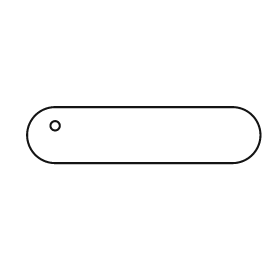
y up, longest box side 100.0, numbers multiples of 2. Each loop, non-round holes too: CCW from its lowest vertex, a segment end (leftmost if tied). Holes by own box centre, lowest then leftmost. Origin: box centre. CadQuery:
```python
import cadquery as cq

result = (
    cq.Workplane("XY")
    .moveTo(-38.0, -12.0)
    .lineTo(38.0, -12.0)
    .threePointArc((50.0, 0.0), (38.0, 12.0))
    .lineTo(-38.0, 12.0)
    .threePointArc((-50.0, 0.0), (-38.0, -12.0))
    .close()
    .moveTo(-38.0, 4.0)
    .circle(2.0)
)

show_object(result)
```